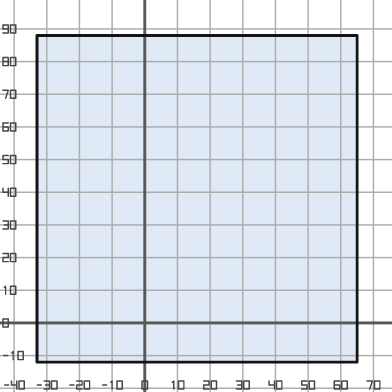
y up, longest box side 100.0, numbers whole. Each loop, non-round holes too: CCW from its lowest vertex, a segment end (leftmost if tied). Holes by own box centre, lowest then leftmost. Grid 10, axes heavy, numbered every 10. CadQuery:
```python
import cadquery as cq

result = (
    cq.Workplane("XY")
    .moveTo(-33.0, -12.0)
    .lineTo(65.0, -12.0)
    .lineTo(65.0, 88.0)
    .lineTo(-33.0, 88.0)
    .close()
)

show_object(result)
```